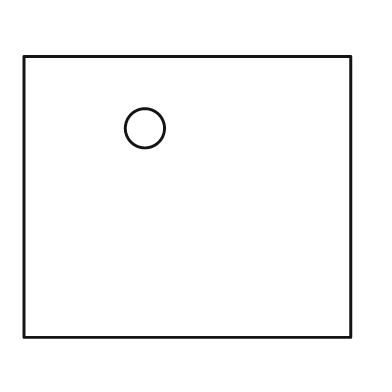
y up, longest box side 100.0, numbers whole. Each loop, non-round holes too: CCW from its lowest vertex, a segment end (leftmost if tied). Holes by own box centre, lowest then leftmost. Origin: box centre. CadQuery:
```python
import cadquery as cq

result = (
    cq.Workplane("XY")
    .moveTo(-50.0, -43.0)
    .lineTo(50.0, -43.0)
    .lineTo(50.0, 43.0)
    .lineTo(-50.0, 43.0)
    .close()
    .moveTo(-13.0, 21.0)
    .circle(6.0)
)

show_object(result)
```